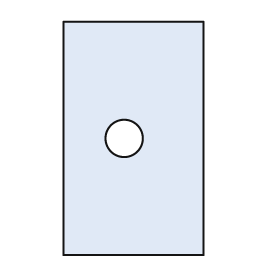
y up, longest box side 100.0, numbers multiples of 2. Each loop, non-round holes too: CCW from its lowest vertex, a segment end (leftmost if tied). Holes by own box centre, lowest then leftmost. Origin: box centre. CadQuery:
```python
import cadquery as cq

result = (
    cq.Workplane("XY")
    .moveTo(-30.0, -50.0)
    .lineTo(30.0, -50.0)
    .lineTo(30.0, 50.0)
    .lineTo(-30.0, 50.0)
    .close()
    .moveTo(-4.0, 0.0)
    .circle(8.0)
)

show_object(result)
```